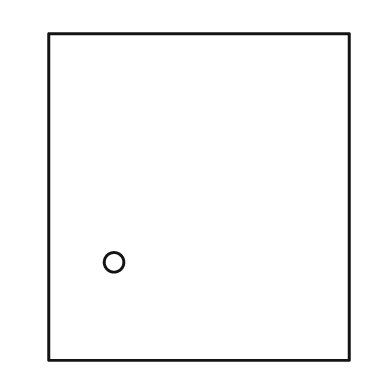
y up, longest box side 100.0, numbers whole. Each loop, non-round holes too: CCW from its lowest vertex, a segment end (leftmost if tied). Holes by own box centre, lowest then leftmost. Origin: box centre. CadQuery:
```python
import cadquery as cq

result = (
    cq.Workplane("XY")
    .moveTo(-46.0, -50.0)
    .lineTo(46.0, -50.0)
    .lineTo(46.0, 50.0)
    .lineTo(-46.0, 50.0)
    .close()
    .moveTo(-26.0, -20.0)
    .circle(3.0)
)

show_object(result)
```